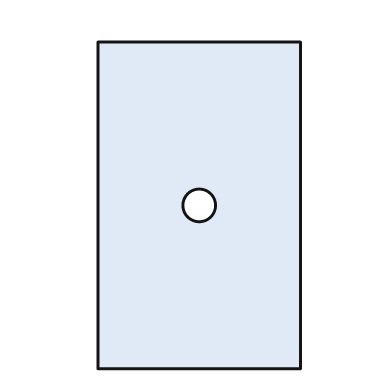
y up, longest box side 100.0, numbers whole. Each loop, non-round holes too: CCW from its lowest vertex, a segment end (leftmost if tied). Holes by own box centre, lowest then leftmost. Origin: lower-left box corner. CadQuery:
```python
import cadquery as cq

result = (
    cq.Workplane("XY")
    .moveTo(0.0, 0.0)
    .lineTo(62.0, 0.0)
    .lineTo(62.0, 100.0)
    .lineTo(0.0, 100.0)
    .close()
    .moveTo(31.0, 50.0)
    .circle(5.0)
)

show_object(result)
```